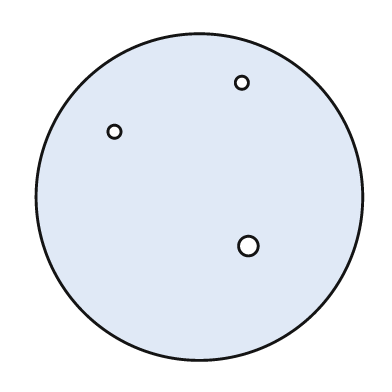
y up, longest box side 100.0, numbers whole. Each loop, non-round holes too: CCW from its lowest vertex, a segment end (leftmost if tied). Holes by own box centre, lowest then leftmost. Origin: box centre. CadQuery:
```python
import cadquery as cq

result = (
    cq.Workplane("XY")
    .moveTo(0.0, 0.0)
    .circle(50.0)
    .moveTo(15.0, -15.0)
    .circle(3.0)
    .moveTo(-26.0, 20.0)
    .circle(2.0)
    .moveTo(13.0, 35.0)
    .circle(2.0)
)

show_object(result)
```